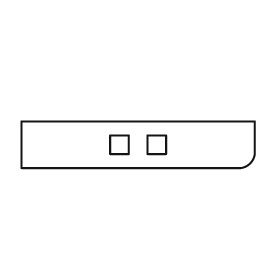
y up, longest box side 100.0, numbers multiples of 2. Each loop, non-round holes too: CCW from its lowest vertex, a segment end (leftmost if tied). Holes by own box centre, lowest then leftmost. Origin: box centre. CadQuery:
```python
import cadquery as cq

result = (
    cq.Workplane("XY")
    .moveTo(-50.0, -10.0)
    .lineTo(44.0, -10.0)
    .threePointArc((48.0, -8.0), (50.0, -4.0))
    .lineTo(50.0, 10.0)
    .lineTo(-50.0, 10.0)
    .close()
    .moveTo(-12.0, -4.0)
    .lineTo(-4.0, -4.0)
    .lineTo(-4.0, 4.0)
    .lineTo(-12.0, 4.0)
    .close()
    .moveTo(4.0, -4.0)
    .lineTo(12.0, -4.0)
    .lineTo(12.0, 4.0)
    .lineTo(4.0, 4.0)
    .close()
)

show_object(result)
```